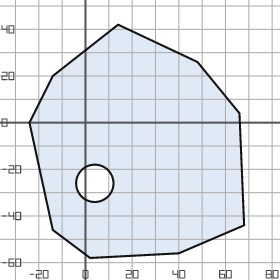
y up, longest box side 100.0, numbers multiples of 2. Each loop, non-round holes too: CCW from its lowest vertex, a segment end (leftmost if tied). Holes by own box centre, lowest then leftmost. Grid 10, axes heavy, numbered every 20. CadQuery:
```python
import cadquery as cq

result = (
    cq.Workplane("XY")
    .moveTo(2.0, -58.0)
    .lineTo(40.0, -56.0)
    .lineTo(68.0, -44.0)
    .lineTo(66.0, 4.0)
    .lineTo(48.0, 26.0)
    .lineTo(14.0, 42.0)
    .lineTo(-14.0, 20.0)
    .lineTo(-24.0, 0.0)
    .lineTo(-14.0, -46.0)
    .close()
    .moveTo(4.0, -26.0)
    .circle(8.0)
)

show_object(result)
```